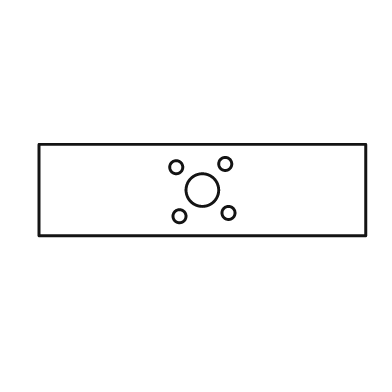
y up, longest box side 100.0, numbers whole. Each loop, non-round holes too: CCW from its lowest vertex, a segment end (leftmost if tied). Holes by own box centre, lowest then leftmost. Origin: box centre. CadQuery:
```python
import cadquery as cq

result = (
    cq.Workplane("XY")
    .moveTo(-50.0, -14.0)
    .lineTo(50.0, -14.0)
    .lineTo(50.0, 14.0)
    .lineTo(-50.0, 14.0)
    .close()
    .moveTo(-7.0, -8.0)
    .circle(2.0)
    .moveTo(8.0, -7.0)
    .circle(2.0)
    .moveTo(0.0, 0.0)
    .circle(5.0)
    .moveTo(-8.0, 7.0)
    .circle(2.0)
    .moveTo(7.0, 8.0)
    .circle(2.0)
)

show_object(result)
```